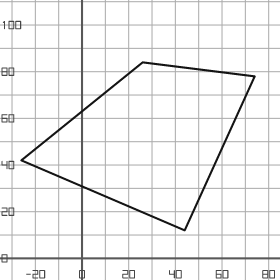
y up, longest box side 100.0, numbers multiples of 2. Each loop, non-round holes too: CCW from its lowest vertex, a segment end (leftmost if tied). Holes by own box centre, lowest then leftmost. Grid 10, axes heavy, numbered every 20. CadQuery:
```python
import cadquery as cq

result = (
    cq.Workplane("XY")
    .moveTo(44.0, 12.0)
    .lineTo(74.0, 78.0)
    .lineTo(26.0, 84.0)
    .lineTo(-26.0, 42.0)
    .close()
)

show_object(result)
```